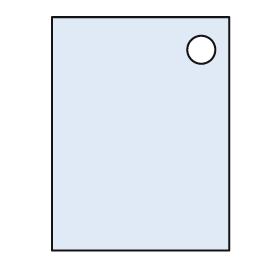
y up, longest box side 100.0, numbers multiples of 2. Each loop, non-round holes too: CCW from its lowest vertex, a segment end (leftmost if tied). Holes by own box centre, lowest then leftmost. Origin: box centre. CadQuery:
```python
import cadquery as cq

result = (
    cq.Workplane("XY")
    .moveTo(-38.0, -50.0)
    .lineTo(38.0, -50.0)
    .lineTo(38.0, 50.0)
    .lineTo(-38.0, 50.0)
    .close()
    .moveTo(26.0, 36.0)
    .circle(6.0)
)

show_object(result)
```